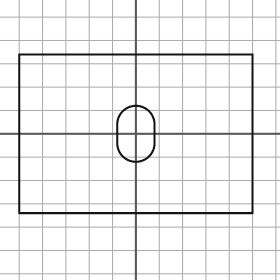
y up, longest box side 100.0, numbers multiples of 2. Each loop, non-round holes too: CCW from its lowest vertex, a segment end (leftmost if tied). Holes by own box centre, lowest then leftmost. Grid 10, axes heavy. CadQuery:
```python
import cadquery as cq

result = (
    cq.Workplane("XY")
    .moveTo(-50.0, -34.0)
    .lineTo(50.0, -34.0)
    .lineTo(50.0, 34.0)
    .lineTo(-50.0, 34.0)
    .close()
    .moveTo(-8.0, -4.0)
    .threePointArc((0.0, -12.0), (8.0, -4.0))
    .lineTo(8.0, 4.0)
    .threePointArc((0.0, 12.0), (-8.0, 4.0))
    .close()
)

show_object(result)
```